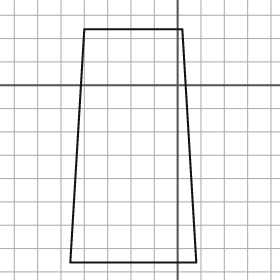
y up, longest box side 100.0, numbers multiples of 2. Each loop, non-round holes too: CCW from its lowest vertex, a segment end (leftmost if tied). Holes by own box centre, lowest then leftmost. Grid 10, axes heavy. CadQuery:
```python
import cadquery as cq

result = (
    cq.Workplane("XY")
    .moveTo(-46.0, -76.0)
    .lineTo(8.0, -76.0)
    .lineTo(2.0, 24.0)
    .lineTo(-40.0, 24.0)
    .close()
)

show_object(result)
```